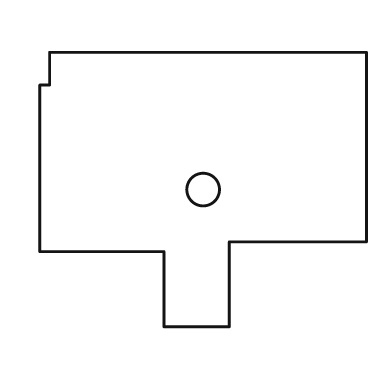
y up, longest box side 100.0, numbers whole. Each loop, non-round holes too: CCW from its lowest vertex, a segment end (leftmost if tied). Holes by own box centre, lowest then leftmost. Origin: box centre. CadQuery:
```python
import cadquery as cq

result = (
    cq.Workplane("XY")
    .moveTo(-12.0, -42.0)
    .lineTo(8.0, -42.0)
    .lineTo(8.0, -16.0)
    .lineTo(50.0, -16.0)
    .lineTo(50.0, 42.0)
    .lineTo(-47.0, 42.0)
    .lineTo(-47.0, 32.0)
    .lineTo(-50.0, 32.0)
    .lineTo(-50.0, -19.0)
    .lineTo(-12.0, -19.0)
    .close()
    .moveTo(0.0, 0.0)
    .circle(5.0)
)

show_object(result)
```